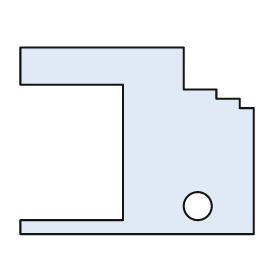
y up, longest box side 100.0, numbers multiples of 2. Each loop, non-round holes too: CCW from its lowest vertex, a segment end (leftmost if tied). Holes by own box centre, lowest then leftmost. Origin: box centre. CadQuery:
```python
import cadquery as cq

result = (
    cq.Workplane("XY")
    .moveTo(-50.0, -40.0)
    .lineTo(50.0, -40.0)
    .lineTo(50.0, 14.0)
    .lineTo(44.0, 14.0)
    .lineTo(44.0, 18.0)
    .lineTo(34.0, 18.0)
    .lineTo(34.0, 22.0)
    .lineTo(20.0, 22.0)
    .lineTo(20.0, 40.0)
    .lineTo(-50.0, 40.0)
    .lineTo(-50.0, 24.0)
    .lineTo(-6.0, 24.0)
    .lineTo(-6.0, -34.0)
    .lineTo(-50.0, -34.0)
    .close()
    .moveTo(26.0, -28.0)
    .circle(6.0)
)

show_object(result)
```